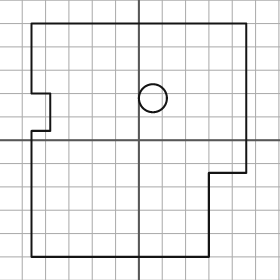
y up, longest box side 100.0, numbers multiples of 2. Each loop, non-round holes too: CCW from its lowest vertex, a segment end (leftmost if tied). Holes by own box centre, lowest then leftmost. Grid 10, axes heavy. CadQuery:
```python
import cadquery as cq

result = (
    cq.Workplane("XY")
    .moveTo(-46.0, -50.0)
    .lineTo(30.0, -50.0)
    .lineTo(30.0, -14.0)
    .lineTo(46.0, -14.0)
    .lineTo(46.0, 50.0)
    .lineTo(-46.0, 50.0)
    .lineTo(-46.0, 20.0)
    .lineTo(-38.0, 20.0)
    .lineTo(-38.0, 4.0)
    .lineTo(-46.0, 4.0)
    .close()
    .moveTo(6.0, 18.0)
    .circle(6.0)
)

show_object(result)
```